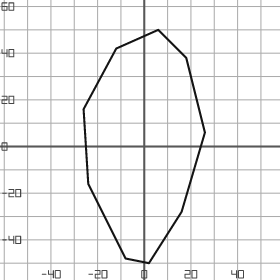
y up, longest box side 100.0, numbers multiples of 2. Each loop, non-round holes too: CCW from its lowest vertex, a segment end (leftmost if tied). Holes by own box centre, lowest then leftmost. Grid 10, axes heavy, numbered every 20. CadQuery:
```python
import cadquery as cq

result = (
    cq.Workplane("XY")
    .moveTo(2.0, -50.0)
    .lineTo(16.0, -28.0)
    .lineTo(26.0, 6.0)
    .lineTo(18.0, 38.0)
    .lineTo(6.0, 50.0)
    .lineTo(-12.0, 42.0)
    .lineTo(-26.0, 16.0)
    .lineTo(-24.0, -16.0)
    .lineTo(-8.0, -48.0)
    .close()
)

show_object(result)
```